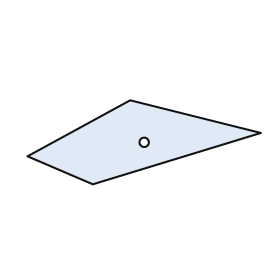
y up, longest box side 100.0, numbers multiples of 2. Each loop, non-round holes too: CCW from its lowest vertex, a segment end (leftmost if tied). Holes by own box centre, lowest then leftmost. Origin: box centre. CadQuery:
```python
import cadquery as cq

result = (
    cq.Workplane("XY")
    .moveTo(-22.0, -18.0)
    .lineTo(50.0, 4.0)
    .lineTo(-6.0, 18.0)
    .lineTo(-50.0, -6.0)
    .close()
    .moveTo(0.0, 0.0)
    .circle(2.0)
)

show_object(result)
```